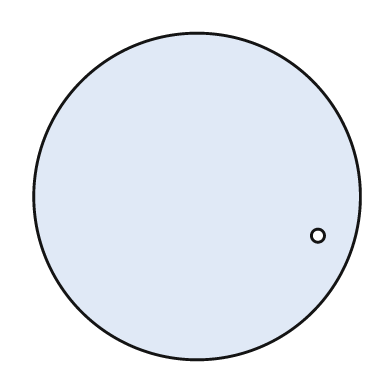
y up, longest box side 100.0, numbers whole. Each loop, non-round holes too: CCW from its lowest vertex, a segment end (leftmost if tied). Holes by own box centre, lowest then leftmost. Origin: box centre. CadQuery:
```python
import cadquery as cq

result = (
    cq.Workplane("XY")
    .moveTo(0.0, 0.0)
    .circle(50.0)
    .moveTo(37.0, -12.0)
    .circle(2.0)
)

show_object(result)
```